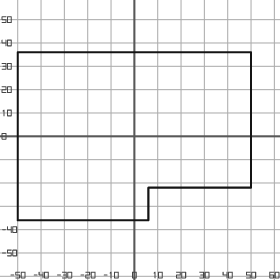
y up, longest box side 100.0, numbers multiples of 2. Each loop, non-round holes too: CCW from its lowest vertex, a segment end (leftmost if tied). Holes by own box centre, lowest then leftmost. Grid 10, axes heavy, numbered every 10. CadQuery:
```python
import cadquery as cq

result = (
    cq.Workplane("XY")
    .moveTo(-50.0, -36.0)
    .lineTo(6.0, -36.0)
    .lineTo(6.0, -22.0)
    .lineTo(50.0, -22.0)
    .lineTo(50.0, 36.0)
    .lineTo(-50.0, 36.0)
    .close()
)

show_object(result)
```